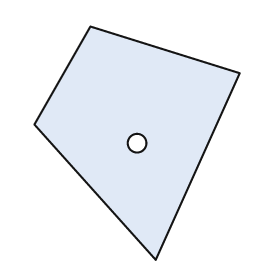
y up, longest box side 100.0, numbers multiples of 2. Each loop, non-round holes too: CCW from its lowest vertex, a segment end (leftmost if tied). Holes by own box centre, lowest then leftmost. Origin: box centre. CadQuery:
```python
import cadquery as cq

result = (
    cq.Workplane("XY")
    .moveTo(8.0, -50.0)
    .lineTo(44.0, 30.0)
    .lineTo(-20.0, 50.0)
    .lineTo(-44.0, 8.0)
    .close()
    .moveTo(0.0, 0.0)
    .circle(4.0)
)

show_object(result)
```